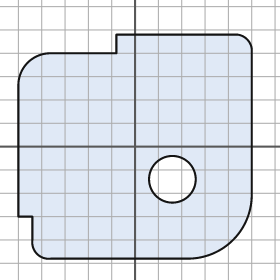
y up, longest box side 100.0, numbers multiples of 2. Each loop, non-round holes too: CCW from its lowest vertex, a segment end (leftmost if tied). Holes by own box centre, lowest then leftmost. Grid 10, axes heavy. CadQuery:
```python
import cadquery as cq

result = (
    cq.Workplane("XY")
    .moveTo(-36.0, -48.0)
    .lineTo(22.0, -48.0)
    .threePointArc((42.0, -40.0), (50.0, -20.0))
    .lineTo(50.0, 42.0)
    .threePointArc((48.0, 46.0), (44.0, 48.0))
    .lineTo(-8.0, 48.0)
    .lineTo(-8.0, 40.0)
    .lineTo(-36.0, 40.0)
    .threePointArc((-46.0, 36.0), (-50.0, 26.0))
    .lineTo(-50.0, -30.0)
    .lineTo(-44.0, -30.0)
    .lineTo(-44.0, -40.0)
    .threePointArc((-42.0, -46.0), (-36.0, -48.0))
    .close()
    .moveTo(16.0, -14.0)
    .circle(10.0)
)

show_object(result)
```